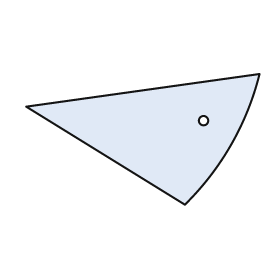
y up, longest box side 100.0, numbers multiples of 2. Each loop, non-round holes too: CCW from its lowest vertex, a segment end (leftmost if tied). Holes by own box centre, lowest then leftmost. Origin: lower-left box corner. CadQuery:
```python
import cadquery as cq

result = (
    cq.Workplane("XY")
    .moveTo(68.0, 0.0)
    .threePointArc((88.0, 26.0), (100.0, 56.0))
    .lineTo(0.0, 42.0)
    .close()
    .moveTo(76.0, 36.0)
    .circle(2.0)
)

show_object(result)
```